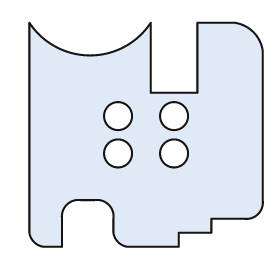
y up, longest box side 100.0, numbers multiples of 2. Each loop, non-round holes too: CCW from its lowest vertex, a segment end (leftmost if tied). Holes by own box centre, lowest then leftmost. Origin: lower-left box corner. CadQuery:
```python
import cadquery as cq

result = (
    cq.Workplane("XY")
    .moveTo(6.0, 0.0)
    .lineTo(14.0, 0.0)
    .lineTo(14.0, 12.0)
    .threePointArc((16.0, 18.0), (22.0, 20.0))
    .lineTo(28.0, 20.0)
    .threePointArc((34.0, 18.0), (36.0, 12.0))
    .lineTo(36.0, 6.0)
    .threePointArc((38.0, 2.0), (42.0, 0.0))
    .lineTo(64.0, 0.0)
    .lineTo(64.0, 6.0)
    .lineTo(78.0, 6.0)
    .lineTo(78.0, 12.0)
    .lineTo(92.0, 12.0)
    .threePointArc((98.0, 14.0), (100.0, 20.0))
    .lineTo(100.0, 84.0)
    .threePointArc((96.0, 92.0), (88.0, 96.0))
    .lineTo(72.0, 96.0)
    .lineTo(72.0, 66.0)
    .lineTo(52.0, 66.0)
    .lineTo(52.0, 96.0)
    .threePointArc((26.0, 82.0), (0.0, 96.0))
    .lineTo(0.0, 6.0)
    .threePointArc((2.0, 2.0), (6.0, 0.0))
    .close()
    .moveTo(38.0, 40.0)
    .circle(6.0)
    .moveTo(62.0, 40.0)
    .circle(6.0)
    .moveTo(38.0, 56.0)
    .circle(6.0)
    .moveTo(62.0, 56.0)
    .circle(6.0)
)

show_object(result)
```